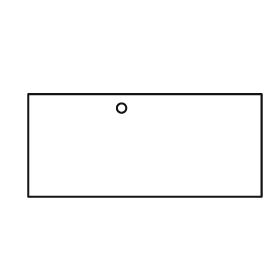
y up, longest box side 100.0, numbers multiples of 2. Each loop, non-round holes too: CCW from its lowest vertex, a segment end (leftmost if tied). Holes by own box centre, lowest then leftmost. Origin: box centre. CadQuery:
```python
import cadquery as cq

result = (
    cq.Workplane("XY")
    .moveTo(-50.0, -22.0)
    .lineTo(50.0, -22.0)
    .lineTo(50.0, 22.0)
    .lineTo(-50.0, 22.0)
    .close()
    .moveTo(-10.0, 16.0)
    .circle(2.0)
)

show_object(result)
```